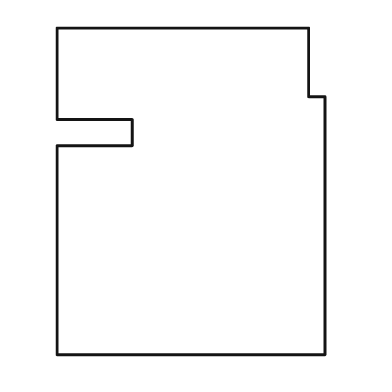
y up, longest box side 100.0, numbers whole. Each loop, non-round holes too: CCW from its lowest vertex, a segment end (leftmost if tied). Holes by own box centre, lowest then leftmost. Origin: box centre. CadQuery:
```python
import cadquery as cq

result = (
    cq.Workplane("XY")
    .moveTo(-41.0, -50.0)
    .lineTo(41.0, -50.0)
    .lineTo(41.0, 29.0)
    .lineTo(36.0, 29.0)
    .lineTo(36.0, 50.0)
    .lineTo(-41.0, 50.0)
    .lineTo(-41.0, 22.0)
    .lineTo(-18.0, 22.0)
    .lineTo(-18.0, 14.0)
    .lineTo(-41.0, 14.0)
    .close()
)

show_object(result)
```